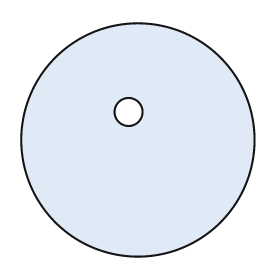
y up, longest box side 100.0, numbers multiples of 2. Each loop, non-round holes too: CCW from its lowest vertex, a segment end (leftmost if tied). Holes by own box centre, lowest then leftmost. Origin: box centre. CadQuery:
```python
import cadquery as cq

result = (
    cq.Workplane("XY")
    .moveTo(0.0, 0.0)
    .circle(50.0)
    .moveTo(-4.0, 12.0)
    .circle(6.0)
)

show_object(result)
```